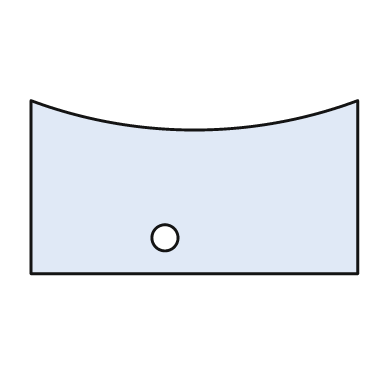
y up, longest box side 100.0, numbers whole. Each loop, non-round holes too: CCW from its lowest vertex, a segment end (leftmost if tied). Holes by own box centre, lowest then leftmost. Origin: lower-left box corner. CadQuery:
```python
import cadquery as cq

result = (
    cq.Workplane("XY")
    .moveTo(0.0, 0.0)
    .lineTo(100.0, 0.0)
    .lineTo(100.0, 53.0)
    .threePointArc((50.0, 44.0), (0.0, 53.0))
    .close()
    .moveTo(41.0, 11.0)
    .circle(4.0)
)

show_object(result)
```